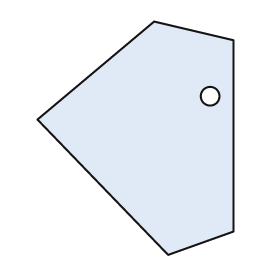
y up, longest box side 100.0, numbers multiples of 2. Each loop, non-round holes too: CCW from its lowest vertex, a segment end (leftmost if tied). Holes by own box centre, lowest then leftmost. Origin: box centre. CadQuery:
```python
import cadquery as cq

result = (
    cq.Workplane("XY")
    .moveTo(14.0, -50.0)
    .lineTo(42.0, -40.0)
    .lineTo(42.0, 42.0)
    .lineTo(8.0, 50.0)
    .lineTo(-42.0, 8.0)
    .close()
    .moveTo(32.0, 18.0)
    .circle(4.0)
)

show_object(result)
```